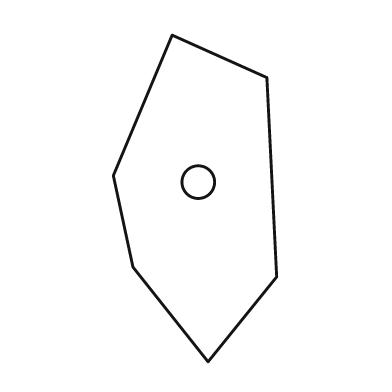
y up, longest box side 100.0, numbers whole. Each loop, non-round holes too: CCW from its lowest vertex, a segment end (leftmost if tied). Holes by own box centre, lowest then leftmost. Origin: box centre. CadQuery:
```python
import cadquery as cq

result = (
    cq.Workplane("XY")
    .moveTo(4.0, -50.0)
    .lineTo(25.0, -24.0)
    .lineTo(22.0, 37.0)
    .lineTo(-7.0, 50.0)
    .lineTo(-25.0, 7.0)
    .lineTo(-19.0, -21.0)
    .close()
    .moveTo(1.0, 5.0)
    .circle(5.0)
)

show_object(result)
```